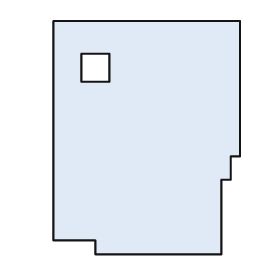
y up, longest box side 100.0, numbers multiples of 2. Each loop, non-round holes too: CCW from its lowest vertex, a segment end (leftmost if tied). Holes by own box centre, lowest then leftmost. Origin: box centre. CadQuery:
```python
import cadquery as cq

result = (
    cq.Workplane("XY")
    .moveTo(-22.0, -50.0)
    .lineTo(32.0, -50.0)
    .lineTo(32.0, -18.0)
    .lineTo(36.0, -18.0)
    .lineTo(36.0, -8.0)
    .lineTo(40.0, -8.0)
    .lineTo(40.0, 50.0)
    .lineTo(-40.0, 50.0)
    .lineTo(-40.0, -44.0)
    .lineTo(-22.0, -44.0)
    .close()
    .moveTo(-28.0, 24.0)
    .lineTo(-16.0, 24.0)
    .lineTo(-16.0, 36.0)
    .lineTo(-28.0, 36.0)
    .close()
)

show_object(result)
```